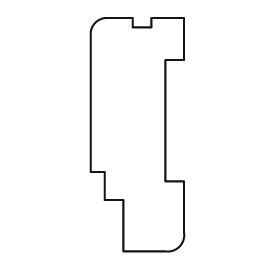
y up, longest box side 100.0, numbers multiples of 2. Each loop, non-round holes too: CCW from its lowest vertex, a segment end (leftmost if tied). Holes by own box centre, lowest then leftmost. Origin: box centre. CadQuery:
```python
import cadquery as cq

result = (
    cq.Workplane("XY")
    .moveTo(-6.0, -50.0)
    .lineTo(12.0, -50.0)
    .threePointArc((18.0, -48.0), (20.0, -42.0))
    .lineTo(20.0, -20.0)
    .lineTo(12.0, -20.0)
    .lineTo(12.0, 32.0)
    .lineTo(20.0, 32.0)
    .lineTo(20.0, 50.0)
    .lineTo(6.0, 50.0)
    .lineTo(6.0, 46.0)
    .lineTo(-2.0, 46.0)
    .lineTo(-2.0, 50.0)
    .lineTo(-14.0, 50.0)
    .threePointArc((-18.0, 48.0), (-20.0, 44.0))
    .lineTo(-20.0, -16.0)
    .lineTo(-14.0, -16.0)
    .lineTo(-14.0, -28.0)
    .lineTo(-6.0, -28.0)
    .close()
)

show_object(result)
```